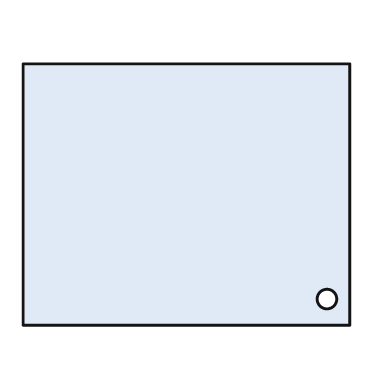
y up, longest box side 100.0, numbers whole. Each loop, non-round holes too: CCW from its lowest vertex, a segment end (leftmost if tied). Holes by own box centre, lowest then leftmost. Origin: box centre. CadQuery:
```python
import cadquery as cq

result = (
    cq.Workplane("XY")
    .moveTo(-50.0, -40.0)
    .lineTo(50.0, -40.0)
    .lineTo(50.0, 40.0)
    .lineTo(-50.0, 40.0)
    .close()
    .moveTo(43.0, -32.0)
    .circle(3.0)
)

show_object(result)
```